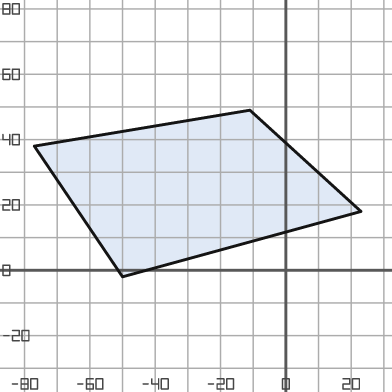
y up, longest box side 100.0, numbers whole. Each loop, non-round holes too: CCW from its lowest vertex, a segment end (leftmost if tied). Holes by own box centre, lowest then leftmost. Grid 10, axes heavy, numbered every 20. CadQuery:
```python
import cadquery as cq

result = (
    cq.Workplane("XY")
    .moveTo(-50.0, -2.0)
    .lineTo(23.0, 18.0)
    .lineTo(-11.0, 49.0)
    .lineTo(-77.0, 38.0)
    .close()
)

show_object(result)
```